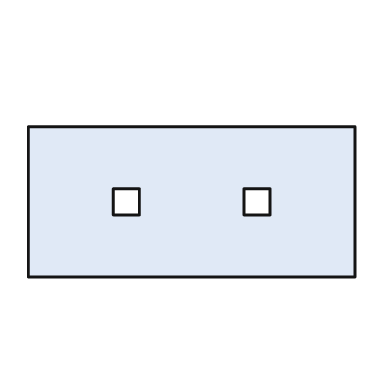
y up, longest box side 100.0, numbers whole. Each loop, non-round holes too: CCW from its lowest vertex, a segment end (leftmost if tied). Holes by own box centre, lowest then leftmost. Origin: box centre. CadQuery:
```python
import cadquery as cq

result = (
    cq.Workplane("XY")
    .moveTo(-50.0, -23.0)
    .lineTo(50.0, -23.0)
    .lineTo(50.0, 23.0)
    .lineTo(-50.0, 23.0)
    .close()
    .moveTo(-24.0, -4.0)
    .lineTo(-16.0, -4.0)
    .lineTo(-16.0, 4.0)
    .lineTo(-24.0, 4.0)
    .close()
    .moveTo(16.0, -4.0)
    .lineTo(24.0, -4.0)
    .lineTo(24.0, 4.0)
    .lineTo(16.0, 4.0)
    .close()
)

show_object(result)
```